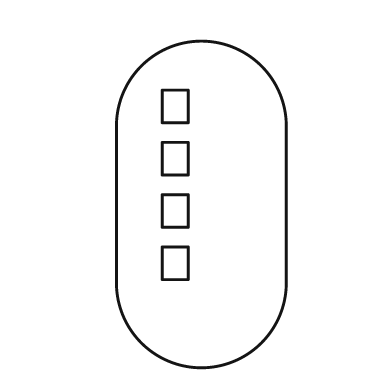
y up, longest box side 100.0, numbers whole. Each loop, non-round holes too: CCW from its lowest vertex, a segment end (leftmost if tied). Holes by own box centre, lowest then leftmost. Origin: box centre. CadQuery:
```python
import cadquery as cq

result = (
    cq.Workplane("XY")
    .moveTo(-26.0, -24.0)
    .threePointArc((0.0, -50.0), (26.0, -24.0))
    .lineTo(26.0, 24.0)
    .threePointArc((0.0, 50.0), (-26.0, 24.0))
    .close()
    .moveTo(-12.0, -23.0)
    .lineTo(-4.0, -23.0)
    .lineTo(-4.0, -13.0)
    .lineTo(-12.0, -13.0)
    .close()
    .moveTo(-12.0, -7.0)
    .lineTo(-4.0, -7.0)
    .lineTo(-4.0, 3.0)
    .lineTo(-12.0, 3.0)
    .close()
    .moveTo(-12.0, 9.0)
    .lineTo(-4.0, 9.0)
    .lineTo(-4.0, 19.0)
    .lineTo(-12.0, 19.0)
    .close()
    .moveTo(-12.0, 25.0)
    .lineTo(-4.0, 25.0)
    .lineTo(-4.0, 35.0)
    .lineTo(-12.0, 35.0)
    .close()
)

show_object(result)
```